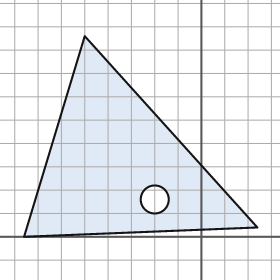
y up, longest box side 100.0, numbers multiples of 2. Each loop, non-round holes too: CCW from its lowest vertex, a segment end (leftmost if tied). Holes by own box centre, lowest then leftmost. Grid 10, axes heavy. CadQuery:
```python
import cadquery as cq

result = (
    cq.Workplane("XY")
    .moveTo(-76.0, 0.0)
    .lineTo(24.0, 4.0)
    .lineTo(-50.0, 86.0)
    .close()
    .moveTo(-20.0, 16.0)
    .circle(6.0)
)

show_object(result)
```